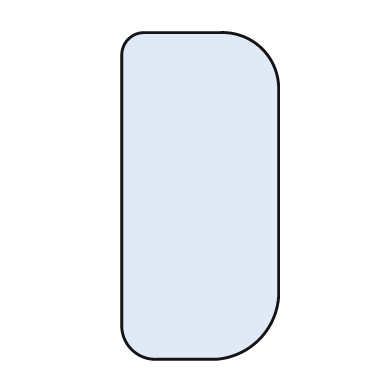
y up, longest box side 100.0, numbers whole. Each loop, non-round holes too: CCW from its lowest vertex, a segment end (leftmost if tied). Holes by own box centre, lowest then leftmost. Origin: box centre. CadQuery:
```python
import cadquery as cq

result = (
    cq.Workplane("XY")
    .moveTo(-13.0, -50.0)
    .lineTo(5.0, -50.0)
    .threePointArc((18.0, -44.0), (24.0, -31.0))
    .lineTo(24.0, 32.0)
    .threePointArc((19.0, 45.0), (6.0, 50.0))
    .lineTo(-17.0, 50.0)
    .threePointArc((-22.0, 48.0), (-24.0, 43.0))
    .lineTo(-24.0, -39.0)
    .threePointArc((-21.0, -47.0), (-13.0, -50.0))
    .close()
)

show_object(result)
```